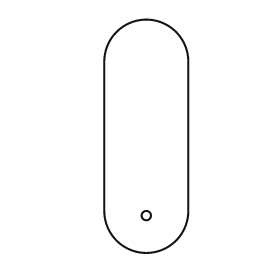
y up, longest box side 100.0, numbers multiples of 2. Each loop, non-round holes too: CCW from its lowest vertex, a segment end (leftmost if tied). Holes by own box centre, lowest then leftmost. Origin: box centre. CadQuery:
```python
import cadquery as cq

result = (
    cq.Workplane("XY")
    .moveTo(-18.0, -32.0)
    .threePointArc((0.0, -50.0), (18.0, -32.0))
    .lineTo(18.0, 32.0)
    .threePointArc((0.0, 50.0), (-18.0, 32.0))
    .close()
    .moveTo(0.0, -34.0)
    .circle(2.0)
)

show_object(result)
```